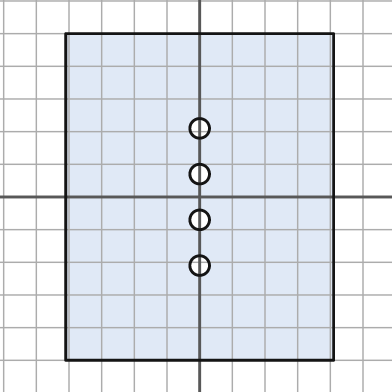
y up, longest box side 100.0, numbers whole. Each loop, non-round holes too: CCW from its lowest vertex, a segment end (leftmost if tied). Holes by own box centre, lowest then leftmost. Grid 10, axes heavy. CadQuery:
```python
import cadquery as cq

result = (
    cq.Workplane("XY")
    .moveTo(-41.0, -50.0)
    .lineTo(41.0, -50.0)
    .lineTo(41.0, 50.0)
    .lineTo(-41.0, 50.0)
    .close()
    .moveTo(0.0, -21.0)
    .circle(3.0)
    .moveTo(0.0, -7.0)
    .circle(3.0)
    .moveTo(0.0, 7.0)
    .circle(3.0)
    .moveTo(0.0, 21.0)
    .circle(3.0)
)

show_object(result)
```